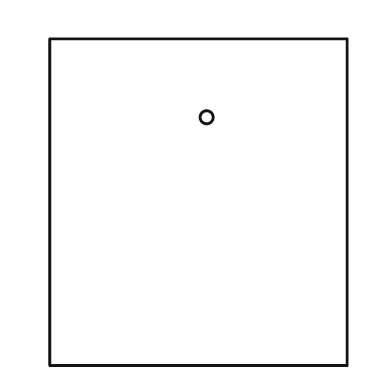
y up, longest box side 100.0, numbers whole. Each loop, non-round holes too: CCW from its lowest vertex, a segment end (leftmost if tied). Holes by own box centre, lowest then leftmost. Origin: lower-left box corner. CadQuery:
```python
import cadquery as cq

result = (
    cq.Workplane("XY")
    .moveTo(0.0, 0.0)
    .lineTo(91.0, 0.0)
    .lineTo(91.0, 100.0)
    .lineTo(0.0, 100.0)
    .close()
    .moveTo(48.0, 76.0)
    .circle(2.0)
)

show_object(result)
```